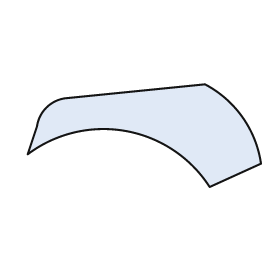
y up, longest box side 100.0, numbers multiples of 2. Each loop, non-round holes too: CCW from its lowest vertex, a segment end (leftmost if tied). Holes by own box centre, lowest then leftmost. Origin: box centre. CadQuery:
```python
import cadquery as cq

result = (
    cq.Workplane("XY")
    .moveTo(28.0, -22.0)
    .lineTo(50.0, -12.0)
    .threePointArc((42.0, 8.0), (26.0, 22.0))
    .lineTo(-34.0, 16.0)
    .threePointArc((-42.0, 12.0), (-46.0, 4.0))
    .lineTo(-50.0, -8.0)
    .threePointArc((-8.0, 2.0), (28.0, -22.0))
    .close()
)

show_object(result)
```